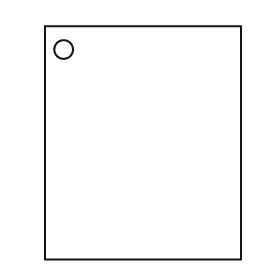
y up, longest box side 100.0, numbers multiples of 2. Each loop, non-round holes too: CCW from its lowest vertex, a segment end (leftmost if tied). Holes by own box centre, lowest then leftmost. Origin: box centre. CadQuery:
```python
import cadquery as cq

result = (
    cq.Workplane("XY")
    .moveTo(-42.0, -50.0)
    .lineTo(42.0, -50.0)
    .lineTo(42.0, 50.0)
    .lineTo(-42.0, 50.0)
    .close()
    .moveTo(-34.0, 40.0)
    .circle(4.0)
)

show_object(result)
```